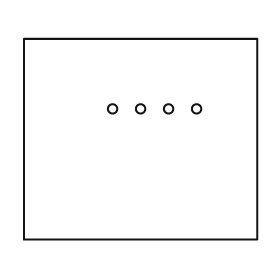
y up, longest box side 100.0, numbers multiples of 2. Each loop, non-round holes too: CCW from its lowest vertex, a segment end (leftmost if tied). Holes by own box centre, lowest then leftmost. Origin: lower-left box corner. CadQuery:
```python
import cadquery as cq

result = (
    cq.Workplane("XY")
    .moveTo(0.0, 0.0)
    .lineTo(100.0, 0.0)
    .lineTo(100.0, 86.0)
    .lineTo(0.0, 86.0)
    .close()
    .moveTo(38.0, 56.0)
    .circle(2.0)
    .moveTo(50.0, 56.0)
    .circle(2.0)
    .moveTo(62.0, 56.0)
    .circle(2.0)
    .moveTo(74.0, 56.0)
    .circle(2.0)
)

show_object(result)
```